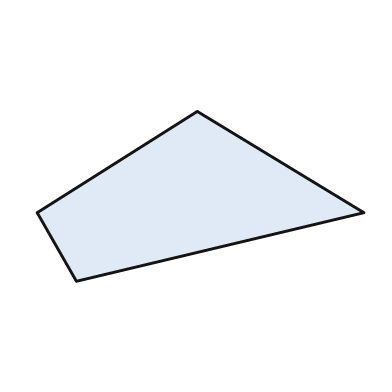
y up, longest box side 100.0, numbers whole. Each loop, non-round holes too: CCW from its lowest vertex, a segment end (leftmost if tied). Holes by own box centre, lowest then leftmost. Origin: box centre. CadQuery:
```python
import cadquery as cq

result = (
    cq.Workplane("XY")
    .moveTo(-38.0, -26.0)
    .lineTo(50.0, -5.0)
    .lineTo(-1.0, 26.0)
    .lineTo(-50.0, -5.0)
    .close()
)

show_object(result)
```